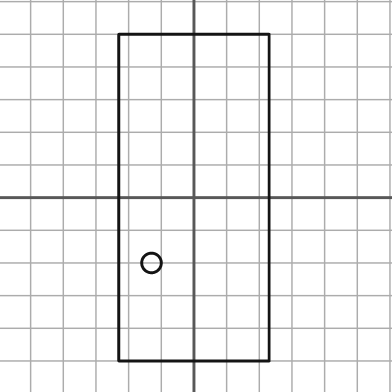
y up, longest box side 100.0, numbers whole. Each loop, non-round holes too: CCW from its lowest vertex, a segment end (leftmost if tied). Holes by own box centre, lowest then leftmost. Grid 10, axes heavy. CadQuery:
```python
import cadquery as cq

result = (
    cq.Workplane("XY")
    .moveTo(-23.0, -50.0)
    .lineTo(23.0, -50.0)
    .lineTo(23.0, 50.0)
    .lineTo(-23.0, 50.0)
    .close()
    .moveTo(-13.0, -20.0)
    .circle(3.0)
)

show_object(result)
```